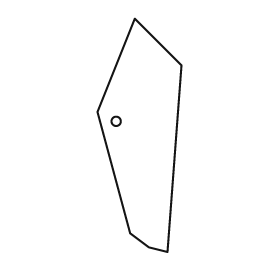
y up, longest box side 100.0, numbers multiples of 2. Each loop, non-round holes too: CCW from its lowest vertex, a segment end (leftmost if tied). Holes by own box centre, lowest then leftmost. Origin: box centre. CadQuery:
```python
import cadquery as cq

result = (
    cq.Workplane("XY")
    .moveTo(12.0, -50.0)
    .lineTo(18.0, 30.0)
    .lineTo(-2.0, 50.0)
    .lineTo(-18.0, 10.0)
    .lineTo(-4.0, -42.0)
    .lineTo(4.0, -48.0)
    .close()
    .moveTo(-10.0, 6.0)
    .circle(2.0)
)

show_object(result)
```